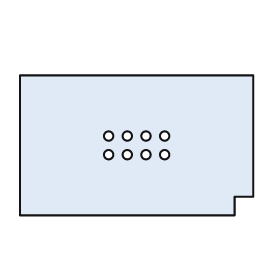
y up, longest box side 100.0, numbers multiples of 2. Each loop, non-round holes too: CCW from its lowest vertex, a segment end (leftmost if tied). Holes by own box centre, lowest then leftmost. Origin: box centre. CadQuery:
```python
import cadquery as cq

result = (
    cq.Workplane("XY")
    .moveTo(-50.0, -30.0)
    .lineTo(42.0, -30.0)
    .lineTo(42.0, -22.0)
    .lineTo(50.0, -22.0)
    .lineTo(50.0, 30.0)
    .lineTo(-50.0, 30.0)
    .close()
    .moveTo(-12.0, -4.0)
    .circle(2.0)
    .moveTo(-4.0, -4.0)
    .circle(2.0)
    .moveTo(4.0, -4.0)
    .circle(2.0)
    .moveTo(12.0, -4.0)
    .circle(2.0)
    .moveTo(-12.0, 4.0)
    .circle(2.0)
    .moveTo(-4.0, 4.0)
    .circle(2.0)
    .moveTo(4.0, 4.0)
    .circle(2.0)
    .moveTo(12.0, 4.0)
    .circle(2.0)
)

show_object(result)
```